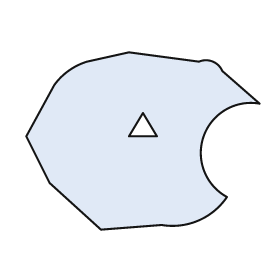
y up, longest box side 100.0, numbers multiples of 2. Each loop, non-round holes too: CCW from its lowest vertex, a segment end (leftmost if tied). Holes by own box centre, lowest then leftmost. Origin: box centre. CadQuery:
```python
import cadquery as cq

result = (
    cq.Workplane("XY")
    .moveTo(-18.0, -38.0)
    .lineTo(8.0, -36.0)
    .threePointArc((24.0, -34.0), (36.0, -24.0))
    .threePointArc((26.0, 2.0), (50.0, 16.0))
    .lineTo(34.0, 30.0)
    .threePointArc((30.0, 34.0), (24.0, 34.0))
    .lineTo(-6.0, 38.0)
    .lineTo(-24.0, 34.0)
    .threePointArc((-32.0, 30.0), (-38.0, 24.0))
    .lineTo(-50.0, 2.0)
    .lineTo(-40.0, -18.0)
    .close()
    .moveTo(-6.0, 2.0)
    .lineTo(6.0, 2.0)
    .lineTo(0.0, 12.0)
    .close()
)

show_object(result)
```